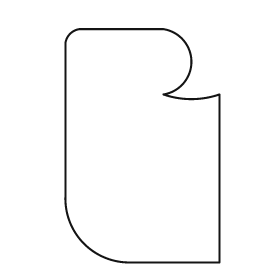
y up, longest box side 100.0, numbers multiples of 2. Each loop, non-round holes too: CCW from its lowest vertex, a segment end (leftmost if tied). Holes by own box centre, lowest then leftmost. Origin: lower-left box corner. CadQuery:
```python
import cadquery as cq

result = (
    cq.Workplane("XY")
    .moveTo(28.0, 0.0)
    .lineTo(66.0, 0.0)
    .lineTo(66.0, 72.0)
    .threePointArc((54.0, 70.0), (42.0, 72.0))
    .threePointArc((54.0, 86.0), (42.0, 100.0))
    .lineTo(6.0, 100.0)
    .threePointArc((2.0, 98.0), (0.0, 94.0))
    .lineTo(0.0, 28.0)
    .threePointArc((8.0, 8.0), (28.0, 0.0))
    .close()
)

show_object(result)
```